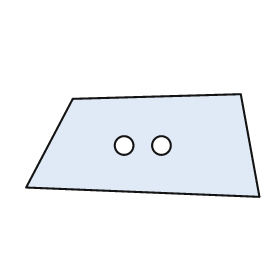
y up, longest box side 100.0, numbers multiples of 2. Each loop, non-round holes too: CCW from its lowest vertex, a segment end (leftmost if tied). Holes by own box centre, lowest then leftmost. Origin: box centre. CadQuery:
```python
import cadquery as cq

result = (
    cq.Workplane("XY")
    .moveTo(50.0, -22.0)
    .lineTo(42.0, 22.0)
    .lineTo(-30.0, 20.0)
    .lineTo(-50.0, -18.0)
    .close()
    .moveTo(-8.0, 0.0)
    .circle(4.0)
    .moveTo(8.0, 0.0)
    .circle(4.0)
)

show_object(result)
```